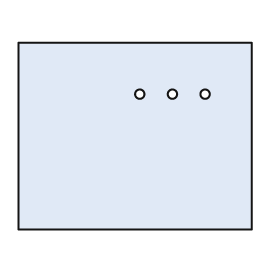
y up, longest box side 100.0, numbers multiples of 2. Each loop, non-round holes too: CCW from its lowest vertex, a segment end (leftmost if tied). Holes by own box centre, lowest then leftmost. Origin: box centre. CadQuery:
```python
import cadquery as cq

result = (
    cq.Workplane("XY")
    .moveTo(-50.0, -40.0)
    .lineTo(50.0, -40.0)
    .lineTo(50.0, 40.0)
    .lineTo(-50.0, 40.0)
    .close()
    .moveTo(2.0, 18.0)
    .circle(2.0)
    .moveTo(16.0, 18.0)
    .circle(2.0)
    .moveTo(30.0, 18.0)
    .circle(2.0)
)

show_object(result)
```